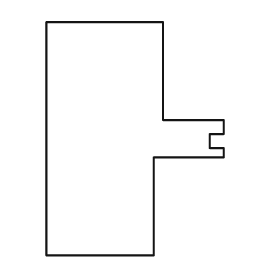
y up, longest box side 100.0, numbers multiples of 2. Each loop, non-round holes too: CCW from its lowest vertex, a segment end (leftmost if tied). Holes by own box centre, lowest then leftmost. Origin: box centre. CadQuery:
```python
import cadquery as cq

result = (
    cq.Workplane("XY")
    .moveTo(-38.0, -50.0)
    .lineTo(8.0, -50.0)
    .lineTo(8.0, -8.0)
    .lineTo(38.0, -8.0)
    .lineTo(38.0, -4.0)
    .lineTo(32.0, -4.0)
    .lineTo(32.0, 2.0)
    .lineTo(38.0, 2.0)
    .lineTo(38.0, 8.0)
    .lineTo(12.0, 8.0)
    .lineTo(12.0, 50.0)
    .lineTo(-38.0, 50.0)
    .close()
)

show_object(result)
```